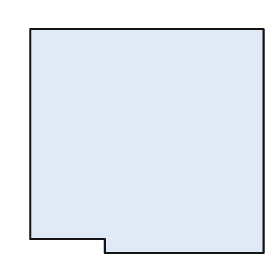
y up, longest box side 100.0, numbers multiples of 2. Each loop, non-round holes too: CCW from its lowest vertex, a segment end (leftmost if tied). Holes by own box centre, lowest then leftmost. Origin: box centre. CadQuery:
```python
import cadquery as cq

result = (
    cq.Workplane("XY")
    .moveTo(-18.0, -48.0)
    .lineTo(50.0, -48.0)
    .lineTo(50.0, 48.0)
    .lineTo(-50.0, 48.0)
    .lineTo(-50.0, -42.0)
    .lineTo(-18.0, -42.0)
    .close()
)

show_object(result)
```